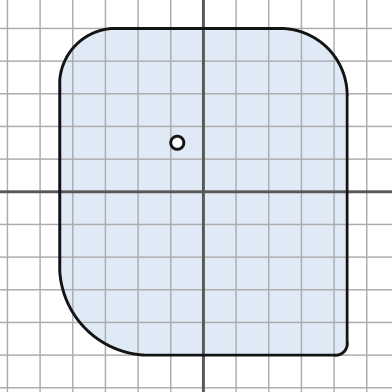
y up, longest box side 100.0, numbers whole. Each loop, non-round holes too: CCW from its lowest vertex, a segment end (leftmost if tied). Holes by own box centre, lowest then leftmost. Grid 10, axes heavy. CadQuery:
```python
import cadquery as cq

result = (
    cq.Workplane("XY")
    .moveTo(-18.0, -50.0)
    .lineTo(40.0, -50.0)
    .threePointArc((43.0, -49.0), (44.0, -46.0))
    .lineTo(44.0, 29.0)
    .threePointArc((38.0, 44.0), (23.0, 50.0))
    .lineTo(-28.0, 50.0)
    .threePointArc((-39.0, 45.0), (-44.0, 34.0))
    .lineTo(-44.0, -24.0)
    .threePointArc((-36.0, -42.0), (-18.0, -50.0))
    .close()
    .moveTo(-8.0, 15.0)
    .circle(2.0)
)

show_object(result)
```